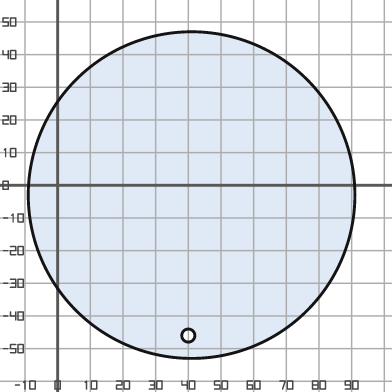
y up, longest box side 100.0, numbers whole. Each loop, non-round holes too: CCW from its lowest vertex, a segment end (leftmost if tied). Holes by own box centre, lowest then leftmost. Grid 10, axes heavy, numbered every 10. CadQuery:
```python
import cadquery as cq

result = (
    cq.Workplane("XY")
    .moveTo(41.0, -3.0)
    .circle(50.0)
    .moveTo(40.0, -46.0)
    .circle(2.0)
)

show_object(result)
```